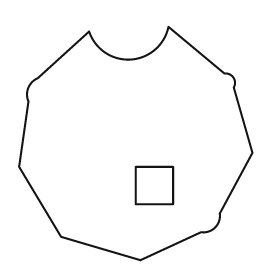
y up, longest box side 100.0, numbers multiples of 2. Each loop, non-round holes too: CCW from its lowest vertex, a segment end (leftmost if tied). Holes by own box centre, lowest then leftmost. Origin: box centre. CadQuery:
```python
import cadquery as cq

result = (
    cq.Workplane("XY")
    .moveTo(2.0, -50.0)
    .lineTo(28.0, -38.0)
    .threePointArc((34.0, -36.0), (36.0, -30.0))
    .lineTo(50.0, -4.0)
    .lineTo(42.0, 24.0)
    .threePointArc((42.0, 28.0), (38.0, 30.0))
    .lineTo(14.0, 50.0)
    .threePointArc((-2.0, 36.0), (-20.0, 48.0))
    .lineTo(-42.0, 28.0)
    .threePointArc((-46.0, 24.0), (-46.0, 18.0))
    .lineTo(-50.0, -10.0)
    .lineTo(-32.0, -40.0)
    .close()
    .moveTo(0.0, -26.0)
    .lineTo(16.0, -26.0)
    .lineTo(16.0, -10.0)
    .lineTo(0.0, -10.0)
    .close()
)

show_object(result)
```